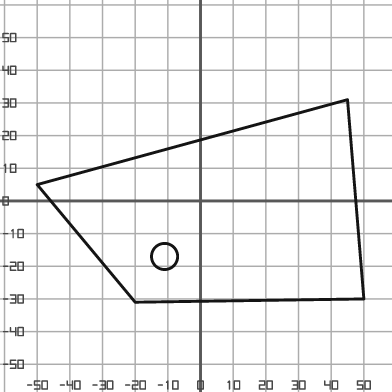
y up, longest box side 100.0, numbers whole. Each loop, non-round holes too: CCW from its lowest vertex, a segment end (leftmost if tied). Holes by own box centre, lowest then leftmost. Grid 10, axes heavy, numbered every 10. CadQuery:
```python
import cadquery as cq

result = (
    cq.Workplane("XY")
    .moveTo(-20.0, -31.0)
    .lineTo(50.0, -30.0)
    .lineTo(45.0, 31.0)
    .lineTo(-50.0, 5.0)
    .close()
    .moveTo(-11.0, -17.0)
    .circle(4.0)
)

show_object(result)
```